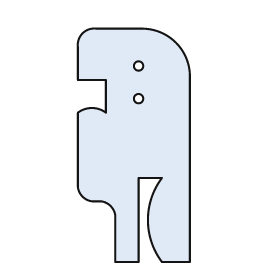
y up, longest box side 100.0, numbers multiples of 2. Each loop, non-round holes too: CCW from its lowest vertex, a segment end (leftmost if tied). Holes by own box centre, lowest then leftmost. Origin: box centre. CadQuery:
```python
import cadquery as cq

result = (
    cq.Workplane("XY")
    .moveTo(-8.0, -50.0)
    .lineTo(2.0, -50.0)
    .lineTo(2.0, -14.0)
    .lineTo(12.0, -14.0)
    .threePointArc((6.0, -32.0), (12.0, -50.0))
    .lineTo(24.0, -50.0)
    .lineTo(24.0, 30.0)
    .threePointArc((18.0, 44.0), (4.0, 50.0))
    .lineTo(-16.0, 50.0)
    .threePointArc((-22.0, 48.0), (-24.0, 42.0))
    .lineTo(-24.0, 28.0)
    .lineTo(-12.0, 28.0)
    .lineTo(-12.0, 14.0)
    .threePointArc((-18.0, 16.0), (-24.0, 14.0))
    .lineTo(-24.0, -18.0)
    .threePointArc((-22.0, -22.0), (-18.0, -24.0))
    .lineTo(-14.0, -24.0)
    .threePointArc((-10.0, -26.0), (-8.0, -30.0))
    .close()
    .moveTo(2.0, 20.0)
    .circle(2.0)
    .moveTo(2.0, 34.0)
    .circle(2.0)
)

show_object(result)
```